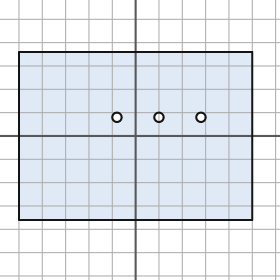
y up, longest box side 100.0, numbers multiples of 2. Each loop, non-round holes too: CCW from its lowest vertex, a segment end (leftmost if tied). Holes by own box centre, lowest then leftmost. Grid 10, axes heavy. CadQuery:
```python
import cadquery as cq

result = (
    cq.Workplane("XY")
    .moveTo(-50.0, -36.0)
    .lineTo(50.0, -36.0)
    .lineTo(50.0, 36.0)
    .lineTo(-50.0, 36.0)
    .close()
    .moveTo(-8.0, 8.0)
    .circle(2.0)
    .moveTo(10.0, 8.0)
    .circle(2.0)
    .moveTo(28.0, 8.0)
    .circle(2.0)
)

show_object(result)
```